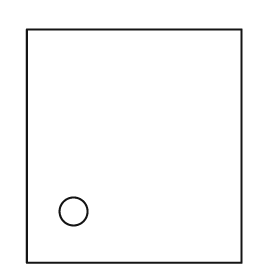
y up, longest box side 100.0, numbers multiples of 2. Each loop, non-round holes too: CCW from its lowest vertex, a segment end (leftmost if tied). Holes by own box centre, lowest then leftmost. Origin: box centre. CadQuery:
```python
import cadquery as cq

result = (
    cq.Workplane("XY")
    .moveTo(-46.0, -50.0)
    .lineTo(46.0, -50.0)
    .lineTo(46.0, 50.0)
    .lineTo(-46.0, 50.0)
    .close()
    .moveTo(-26.0, -28.0)
    .circle(6.0)
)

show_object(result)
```